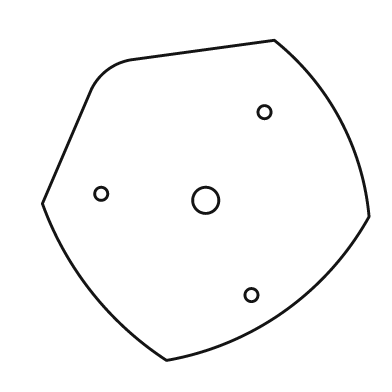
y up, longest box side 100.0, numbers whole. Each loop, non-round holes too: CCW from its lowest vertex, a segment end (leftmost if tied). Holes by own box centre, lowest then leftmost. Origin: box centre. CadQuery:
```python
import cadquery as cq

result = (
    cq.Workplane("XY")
    .moveTo(-12.0, -49.0)
    .threePointArc((24.0, -34.0), (50.0, -5.0))
    .threePointArc((41.0, 25.0), (21.0, 49.0))
    .lineTo(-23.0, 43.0)
    .threePointArc((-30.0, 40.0), (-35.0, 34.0))
    .lineTo(-50.0, -1.0)
    .threePointArc((-35.0, -28.0), (-12.0, -49.0))
    .close()
    .moveTo(14.0, -29.0)
    .circle(2.0)
    .moveTo(0.0, 0.0)
    .circle(4.0)
    .moveTo(-32.0, 2.0)
    .circle(2.0)
    .moveTo(18.0, 27.0)
    .circle(2.0)
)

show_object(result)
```